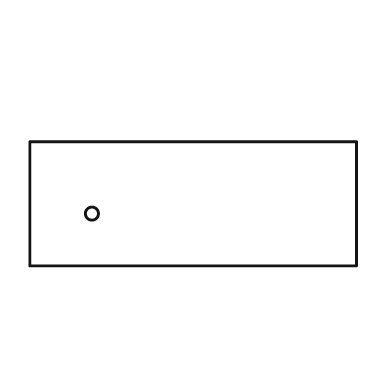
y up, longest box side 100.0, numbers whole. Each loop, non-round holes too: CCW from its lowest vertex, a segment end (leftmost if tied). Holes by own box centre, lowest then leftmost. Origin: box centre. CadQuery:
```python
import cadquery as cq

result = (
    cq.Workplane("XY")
    .moveTo(-50.0, -19.0)
    .lineTo(50.0, -19.0)
    .lineTo(50.0, 19.0)
    .lineTo(-50.0, 19.0)
    .close()
    .moveTo(-31.0, -3.0)
    .circle(2.0)
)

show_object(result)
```